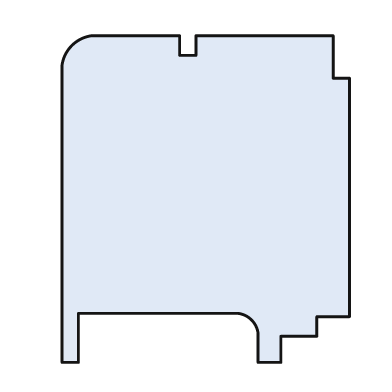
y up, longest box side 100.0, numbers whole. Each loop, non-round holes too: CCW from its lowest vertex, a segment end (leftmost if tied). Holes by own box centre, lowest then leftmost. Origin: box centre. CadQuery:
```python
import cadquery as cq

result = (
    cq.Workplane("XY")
    .moveTo(-44.0, -50.0)
    .lineTo(-39.0, -50.0)
    .lineTo(-39.0, -35.0)
    .lineTo(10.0, -35.0)
    .threePointArc((14.0, -37.0), (16.0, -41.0))
    .lineTo(16.0, -50.0)
    .lineTo(23.0, -50.0)
    .lineTo(23.0, -42.0)
    .lineTo(34.0, -42.0)
    .lineTo(34.0, -36.0)
    .lineTo(44.0, -36.0)
    .lineTo(44.0, 37.0)
    .lineTo(39.0, 37.0)
    .lineTo(39.0, 50.0)
    .lineTo(-3.0, 50.0)
    .lineTo(-3.0, 44.0)
    .lineTo(-8.0, 44.0)
    .lineTo(-8.0, 50.0)
    .lineTo(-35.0, 50.0)
    .threePointArc((-41.0, 47.0), (-44.0, 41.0))
    .close()
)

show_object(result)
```